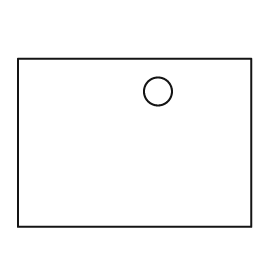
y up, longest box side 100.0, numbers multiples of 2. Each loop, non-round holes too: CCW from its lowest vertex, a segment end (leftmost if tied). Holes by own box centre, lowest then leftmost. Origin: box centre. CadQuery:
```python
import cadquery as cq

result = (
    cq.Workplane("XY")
    .moveTo(-50.0, -36.0)
    .lineTo(50.0, -36.0)
    .lineTo(50.0, 36.0)
    .lineTo(-50.0, 36.0)
    .close()
    .moveTo(10.0, 22.0)
    .circle(6.0)
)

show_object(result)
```